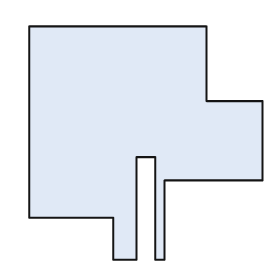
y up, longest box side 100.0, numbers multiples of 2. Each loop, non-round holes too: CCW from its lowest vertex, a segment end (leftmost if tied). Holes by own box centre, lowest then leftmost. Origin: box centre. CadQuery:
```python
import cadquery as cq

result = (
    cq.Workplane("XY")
    .moveTo(-14.0, -50.0)
    .lineTo(-4.0, -50.0)
    .lineTo(-4.0, -6.0)
    .lineTo(4.0, -6.0)
    .lineTo(4.0, -50.0)
    .lineTo(8.0, -50.0)
    .lineTo(8.0, -16.0)
    .lineTo(50.0, -16.0)
    .lineTo(50.0, 18.0)
    .lineTo(26.0, 18.0)
    .lineTo(26.0, 50.0)
    .lineTo(-50.0, 50.0)
    .lineTo(-50.0, -32.0)
    .lineTo(-14.0, -32.0)
    .close()
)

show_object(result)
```